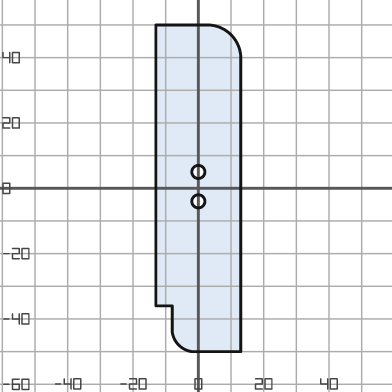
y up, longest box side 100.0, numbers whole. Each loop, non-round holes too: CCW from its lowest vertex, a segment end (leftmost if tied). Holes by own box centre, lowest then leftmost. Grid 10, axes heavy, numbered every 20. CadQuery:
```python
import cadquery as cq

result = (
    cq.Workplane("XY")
    .moveTo(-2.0, -50.0)
    .lineTo(13.0, -50.0)
    .lineTo(13.0, 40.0)
    .threePointArc((10.0, 47.0), (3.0, 50.0))
    .lineTo(-13.0, 50.0)
    .lineTo(-13.0, -36.0)
    .lineTo(-8.0, -36.0)
    .lineTo(-8.0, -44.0)
    .threePointArc((-6.0, -48.0), (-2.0, -50.0))
    .close()
    .moveTo(0.0, -4.0)
    .circle(2.0)
    .moveTo(0.0, 5.0)
    .circle(2.0)
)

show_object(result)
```